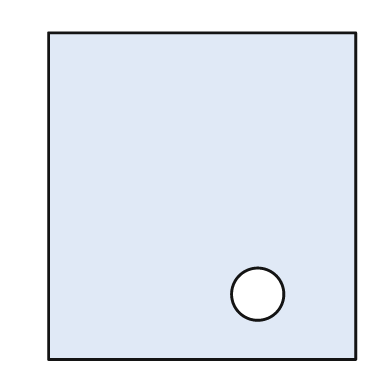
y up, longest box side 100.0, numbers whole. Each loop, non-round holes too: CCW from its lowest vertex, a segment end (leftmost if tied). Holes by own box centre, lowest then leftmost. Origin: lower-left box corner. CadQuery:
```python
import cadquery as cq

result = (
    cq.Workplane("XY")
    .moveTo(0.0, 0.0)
    .lineTo(94.0, 0.0)
    .lineTo(94.0, 100.0)
    .lineTo(0.0, 100.0)
    .close()
    .moveTo(64.0, 20.0)
    .circle(8.0)
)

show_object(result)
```